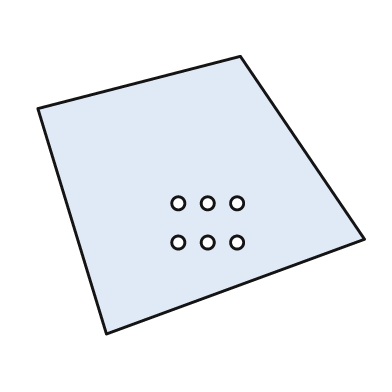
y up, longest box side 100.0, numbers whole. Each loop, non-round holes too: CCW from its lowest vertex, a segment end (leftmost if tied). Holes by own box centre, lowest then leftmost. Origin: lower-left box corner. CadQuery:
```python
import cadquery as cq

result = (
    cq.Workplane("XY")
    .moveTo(21.0, 0.0)
    .lineTo(100.0, 29.0)
    .lineTo(62.0, 85.0)
    .lineTo(0.0, 69.0)
    .close()
    .moveTo(43.0, 28.0)
    .circle(2.0)
    .moveTo(52.0, 28.0)
    .circle(2.0)
    .moveTo(61.0, 28.0)
    .circle(2.0)
    .moveTo(43.0, 40.0)
    .circle(2.0)
    .moveTo(52.0, 40.0)
    .circle(2.0)
    .moveTo(61.0, 40.0)
    .circle(2.0)
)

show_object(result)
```